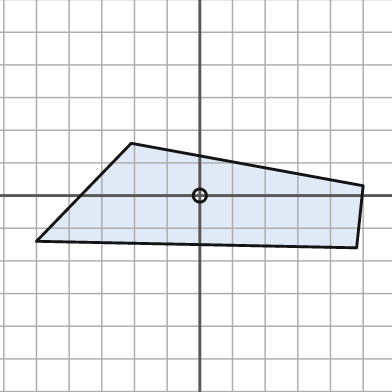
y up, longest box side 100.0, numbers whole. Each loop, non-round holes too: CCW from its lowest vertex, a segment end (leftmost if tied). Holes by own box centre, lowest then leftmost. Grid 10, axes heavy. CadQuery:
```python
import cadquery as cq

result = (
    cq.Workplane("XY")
    .moveTo(48.0, -16.0)
    .lineTo(50.0, 3.0)
    .lineTo(-21.0, 16.0)
    .lineTo(-50.0, -14.0)
    .close()
    .moveTo(0.0, 0.0)
    .circle(2.0)
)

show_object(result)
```